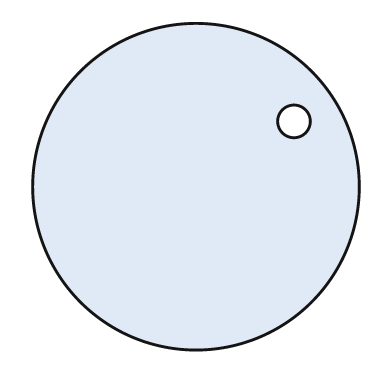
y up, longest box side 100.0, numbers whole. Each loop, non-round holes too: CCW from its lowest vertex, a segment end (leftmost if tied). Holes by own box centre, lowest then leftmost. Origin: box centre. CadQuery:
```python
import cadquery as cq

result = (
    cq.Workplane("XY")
    .moveTo(0.0, 0.0)
    .circle(50.0)
    .moveTo(30.0, 20.0)
    .circle(5.0)
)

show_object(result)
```